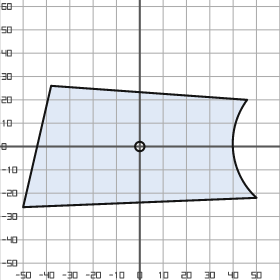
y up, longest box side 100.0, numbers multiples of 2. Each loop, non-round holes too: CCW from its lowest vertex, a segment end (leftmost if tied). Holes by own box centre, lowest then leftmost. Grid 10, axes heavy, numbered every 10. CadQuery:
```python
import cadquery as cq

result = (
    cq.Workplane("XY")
    .moveTo(-50.0, -26.0)
    .lineTo(50.0, -22.0)
    .threePointArc((40.0, -2.0), (46.0, 20.0))
    .lineTo(-38.0, 26.0)
    .close()
    .moveTo(0.0, 0.0)
    .circle(2.0)
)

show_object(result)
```